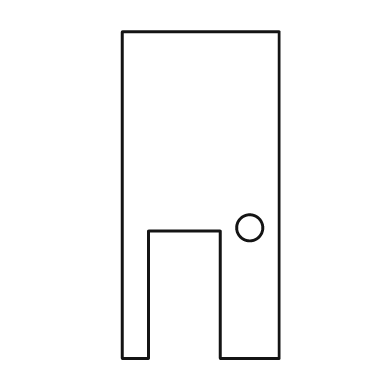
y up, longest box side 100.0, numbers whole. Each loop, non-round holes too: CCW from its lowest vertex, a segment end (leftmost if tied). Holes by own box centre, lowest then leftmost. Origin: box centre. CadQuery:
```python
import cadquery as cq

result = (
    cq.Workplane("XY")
    .moveTo(-24.0, -50.0)
    .lineTo(-16.0, -50.0)
    .lineTo(-16.0, -11.0)
    .lineTo(6.0, -11.0)
    .lineTo(6.0, -50.0)
    .lineTo(24.0, -50.0)
    .lineTo(24.0, 50.0)
    .lineTo(-24.0, 50.0)
    .close()
    .moveTo(15.0, -10.0)
    .circle(4.0)
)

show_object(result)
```